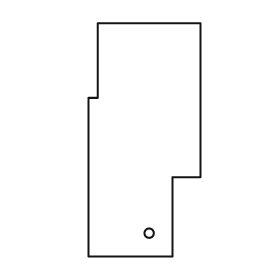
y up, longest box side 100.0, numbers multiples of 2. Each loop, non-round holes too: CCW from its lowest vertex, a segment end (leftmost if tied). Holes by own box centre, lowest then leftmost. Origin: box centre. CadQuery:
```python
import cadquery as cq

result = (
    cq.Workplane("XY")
    .moveTo(-24.0, -50.0)
    .lineTo(12.0, -50.0)
    .lineTo(12.0, -16.0)
    .lineTo(24.0, -16.0)
    .lineTo(24.0, 50.0)
    .lineTo(-20.0, 50.0)
    .lineTo(-20.0, 18.0)
    .lineTo(-24.0, 18.0)
    .close()
    .moveTo(2.0, -40.0)
    .circle(2.0)
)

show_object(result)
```